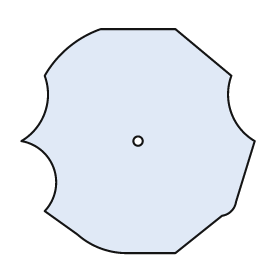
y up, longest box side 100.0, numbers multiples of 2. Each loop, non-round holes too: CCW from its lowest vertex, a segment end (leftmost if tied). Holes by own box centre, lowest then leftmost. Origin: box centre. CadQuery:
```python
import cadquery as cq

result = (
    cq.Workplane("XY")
    .moveTo(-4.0, -48.0)
    .lineTo(16.0, -48.0)
    .lineTo(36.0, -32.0)
    .threePointArc((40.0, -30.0), (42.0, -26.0))
    .lineTo(50.0, 0.0)
    .threePointArc((40.0, 12.0), (40.0, 28.0))
    .lineTo(16.0, 48.0)
    .lineTo(-16.0, 48.0)
    .threePointArc((-30.0, 40.0), (-40.0, 28.0))
    .threePointArc((-40.0, 12.0), (-50.0, 0.0))
    .threePointArc((-36.0, -12.0), (-40.0, -30.0))
    .lineTo(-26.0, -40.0)
    .threePointArc((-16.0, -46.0), (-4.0, -48.0))
    .close()
    .moveTo(0.0, 0.0)
    .circle(2.0)
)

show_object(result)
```